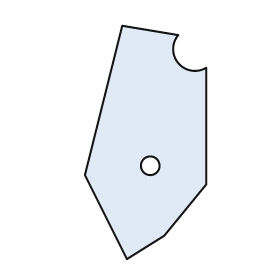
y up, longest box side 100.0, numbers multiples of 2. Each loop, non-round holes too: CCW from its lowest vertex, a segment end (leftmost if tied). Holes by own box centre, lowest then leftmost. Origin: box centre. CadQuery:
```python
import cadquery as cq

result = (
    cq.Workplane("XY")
    .moveTo(-8.0, -50.0)
    .lineTo(8.0, -40.0)
    .lineTo(26.0, -18.0)
    .lineTo(26.0, 32.0)
    .threePointArc((14.0, 34.0), (14.0, 46.0))
    .lineTo(-10.0, 50.0)
    .lineTo(-26.0, -14.0)
    .close()
    .moveTo(2.0, -10.0)
    .circle(4.0)
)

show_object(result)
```